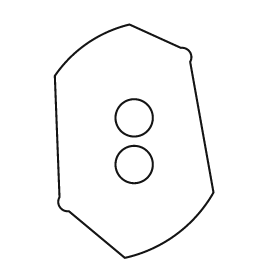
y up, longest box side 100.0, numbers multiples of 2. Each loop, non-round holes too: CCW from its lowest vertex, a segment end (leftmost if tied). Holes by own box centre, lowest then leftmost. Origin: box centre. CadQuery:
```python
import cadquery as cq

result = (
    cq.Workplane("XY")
    .moveTo(-4.0, -50.0)
    .threePointArc((18.0, -40.0), (34.0, -22.0))
    .lineTo(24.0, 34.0)
    .threePointArc((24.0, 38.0), (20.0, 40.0))
    .lineTo(-2.0, 50.0)
    .threePointArc((-20.0, 42.0), (-34.0, 28.0))
    .lineTo(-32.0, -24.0)
    .threePointArc((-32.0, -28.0), (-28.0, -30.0))
    .close()
    .moveTo(0.0, -10.0)
    .circle(8.0)
    .moveTo(0.0, 10.0)
    .circle(8.0)
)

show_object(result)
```